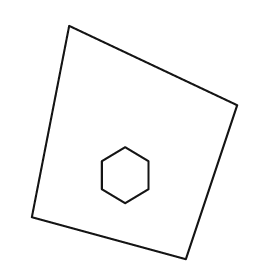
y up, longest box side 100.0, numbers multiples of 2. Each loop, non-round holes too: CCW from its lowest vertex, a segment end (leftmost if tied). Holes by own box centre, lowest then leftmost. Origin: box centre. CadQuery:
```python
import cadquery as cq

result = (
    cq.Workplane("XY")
    .moveTo(22.0, -50.0)
    .lineTo(44.0, 16.0)
    .lineTo(-28.0, 50.0)
    .lineTo(-44.0, -32.0)
    .close()
    .moveTo(-4.0, -26.0)
    .lineTo(6.0, -20.0)
    .lineTo(6.0, -8.0)
    .lineTo(-4.0, -2.0)
    .lineTo(-14.0, -8.0)
    .lineTo(-14.0, -20.0)
    .close()
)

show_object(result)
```